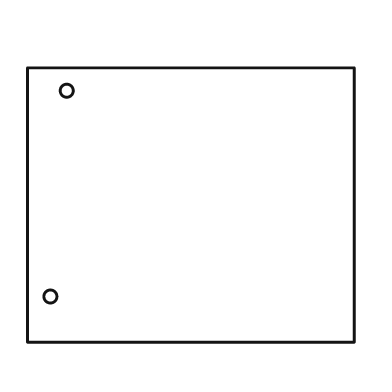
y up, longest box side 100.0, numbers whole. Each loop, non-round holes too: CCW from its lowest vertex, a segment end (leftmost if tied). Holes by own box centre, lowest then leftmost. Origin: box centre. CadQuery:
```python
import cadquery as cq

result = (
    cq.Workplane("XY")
    .moveTo(-50.0, -42.0)
    .lineTo(50.0, -42.0)
    .lineTo(50.0, 42.0)
    .lineTo(-50.0, 42.0)
    .close()
    .moveTo(-43.0, -28.0)
    .circle(2.0)
    .moveTo(-38.0, 35.0)
    .circle(2.0)
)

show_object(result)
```